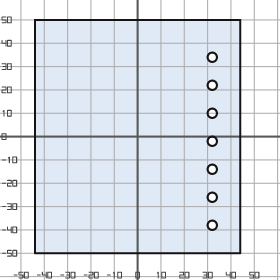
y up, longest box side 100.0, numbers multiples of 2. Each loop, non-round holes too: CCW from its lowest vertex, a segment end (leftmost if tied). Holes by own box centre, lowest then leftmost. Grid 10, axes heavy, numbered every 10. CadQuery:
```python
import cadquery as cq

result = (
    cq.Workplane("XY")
    .moveTo(-44.0, -50.0)
    .lineTo(44.0, -50.0)
    .lineTo(44.0, 50.0)
    .lineTo(-44.0, 50.0)
    .close()
    .moveTo(32.0, -38.0)
    .circle(2.0)
    .moveTo(32.0, -26.0)
    .circle(2.0)
    .moveTo(32.0, -14.0)
    .circle(2.0)
    .moveTo(32.0, -2.0)
    .circle(2.0)
    .moveTo(32.0, 10.0)
    .circle(2.0)
    .moveTo(32.0, 22.0)
    .circle(2.0)
    .moveTo(32.0, 34.0)
    .circle(2.0)
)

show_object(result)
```